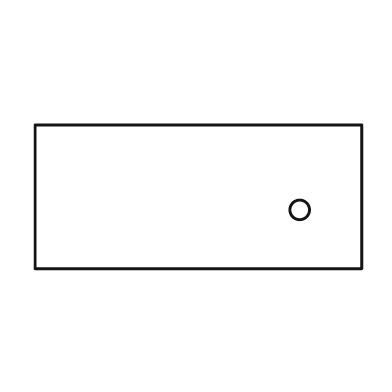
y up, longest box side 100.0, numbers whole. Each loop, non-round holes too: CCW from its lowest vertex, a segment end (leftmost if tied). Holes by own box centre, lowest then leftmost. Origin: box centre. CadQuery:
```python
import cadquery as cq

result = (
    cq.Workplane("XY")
    .moveTo(-50.0, -22.0)
    .lineTo(50.0, -22.0)
    .lineTo(50.0, 22.0)
    .lineTo(-50.0, 22.0)
    .close()
    .moveTo(31.0, -4.0)
    .circle(3.0)
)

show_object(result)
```